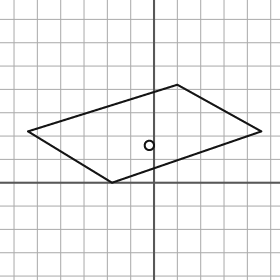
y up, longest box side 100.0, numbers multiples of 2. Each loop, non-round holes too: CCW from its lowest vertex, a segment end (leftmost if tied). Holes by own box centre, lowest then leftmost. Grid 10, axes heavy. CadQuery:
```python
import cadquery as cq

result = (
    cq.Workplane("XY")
    .moveTo(-18.0, 0.0)
    .lineTo(46.0, 22.0)
    .lineTo(10.0, 42.0)
    .lineTo(-54.0, 22.0)
    .close()
    .moveTo(-2.0, 16.0)
    .circle(2.0)
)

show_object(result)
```